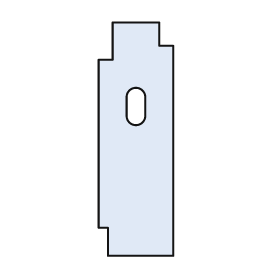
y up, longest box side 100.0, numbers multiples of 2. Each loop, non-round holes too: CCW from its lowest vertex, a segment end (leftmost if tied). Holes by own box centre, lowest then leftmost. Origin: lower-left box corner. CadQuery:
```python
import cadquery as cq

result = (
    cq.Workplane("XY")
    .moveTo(4.0, 0.0)
    .lineTo(32.0, 0.0)
    .lineTo(32.0, 90.0)
    .lineTo(26.0, 90.0)
    .lineTo(26.0, 100.0)
    .lineTo(6.0, 100.0)
    .lineTo(6.0, 84.0)
    .lineTo(0.0, 84.0)
    .lineTo(0.0, 12.0)
    .lineTo(4.0, 12.0)
    .close()
    .moveTo(12.0, 60.0)
    .threePointArc((16.0, 56.0), (20.0, 60.0))
    .lineTo(20.0, 68.0)
    .threePointArc((16.0, 72.0), (12.0, 68.0))
    .close()
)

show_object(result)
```